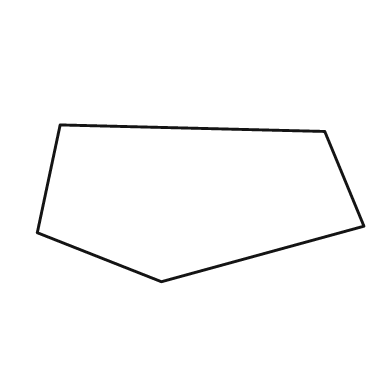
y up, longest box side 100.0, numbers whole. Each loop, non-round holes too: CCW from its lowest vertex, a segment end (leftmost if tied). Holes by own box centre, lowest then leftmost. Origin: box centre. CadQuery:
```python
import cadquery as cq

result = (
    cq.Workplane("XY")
    .moveTo(-12.0, -24.0)
    .lineTo(50.0, -7.0)
    .lineTo(38.0, 22.0)
    .lineTo(-43.0, 24.0)
    .lineTo(-50.0, -9.0)
    .close()
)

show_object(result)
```